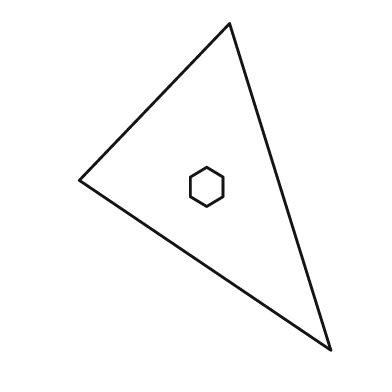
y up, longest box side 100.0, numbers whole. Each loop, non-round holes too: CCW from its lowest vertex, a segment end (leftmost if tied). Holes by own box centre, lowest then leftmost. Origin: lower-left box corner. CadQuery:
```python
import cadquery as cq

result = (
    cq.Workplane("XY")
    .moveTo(77.0, 0.0)
    .lineTo(46.0, 100.0)
    .lineTo(0.0, 52.0)
    .close()
    .moveTo(39.0, 44.0)
    .lineTo(44.0, 47.0)
    .lineTo(44.0, 53.0)
    .lineTo(39.0, 56.0)
    .lineTo(34.0, 53.0)
    .lineTo(34.0, 47.0)
    .close()
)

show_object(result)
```